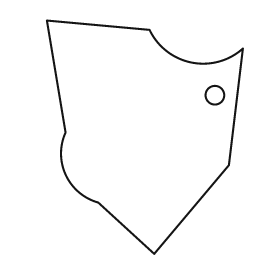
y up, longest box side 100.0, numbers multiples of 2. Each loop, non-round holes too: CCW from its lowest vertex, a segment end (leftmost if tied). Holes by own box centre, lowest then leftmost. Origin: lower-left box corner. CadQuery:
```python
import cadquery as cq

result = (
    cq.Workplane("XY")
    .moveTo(46.0, 0.0)
    .lineTo(78.0, 38.0)
    .lineTo(84.0, 88.0)
    .threePointArc((62.0, 82.0), (44.0, 96.0))
    .lineTo(0.0, 100.0)
    .lineTo(8.0, 52.0)
    .threePointArc((8.0, 34.0), (22.0, 22.0))
    .close()
    .moveTo(72.0, 68.0)
    .circle(4.0)
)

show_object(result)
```